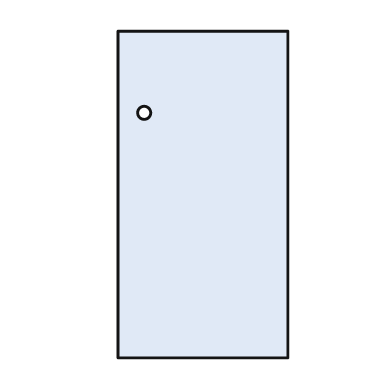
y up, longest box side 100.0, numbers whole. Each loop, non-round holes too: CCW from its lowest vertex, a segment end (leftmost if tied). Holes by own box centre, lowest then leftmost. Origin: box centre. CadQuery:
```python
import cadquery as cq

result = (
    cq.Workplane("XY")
    .moveTo(-26.0, -50.0)
    .lineTo(26.0, -50.0)
    .lineTo(26.0, 50.0)
    .lineTo(-26.0, 50.0)
    .close()
    .moveTo(-18.0, 25.0)
    .circle(2.0)
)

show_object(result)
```